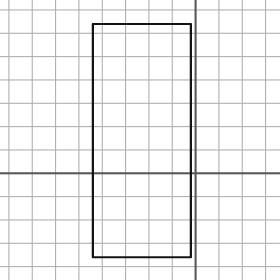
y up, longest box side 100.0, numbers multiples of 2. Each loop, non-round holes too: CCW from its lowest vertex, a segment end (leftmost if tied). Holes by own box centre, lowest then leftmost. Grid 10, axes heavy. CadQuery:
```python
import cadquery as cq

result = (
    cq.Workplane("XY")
    .moveTo(-44.0, -36.0)
    .lineTo(-2.0, -36.0)
    .lineTo(-2.0, 64.0)
    .lineTo(-44.0, 64.0)
    .close()
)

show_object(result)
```